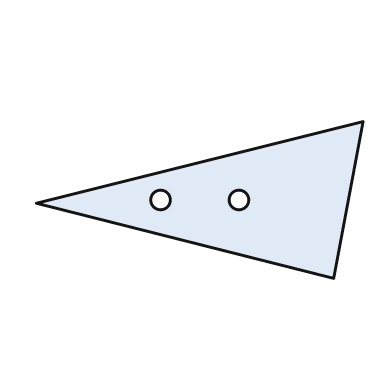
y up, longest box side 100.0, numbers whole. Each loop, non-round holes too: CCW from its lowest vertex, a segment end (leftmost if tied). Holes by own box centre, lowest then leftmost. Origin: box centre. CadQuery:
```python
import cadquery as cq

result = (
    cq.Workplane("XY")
    .moveTo(41.0, -24.0)
    .lineTo(50.0, 24.0)
    .lineTo(-50.0, -1.0)
    .close()
    .moveTo(-12.0, 0.0)
    .circle(3.0)
    .moveTo(12.0, 0.0)
    .circle(3.0)
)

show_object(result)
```